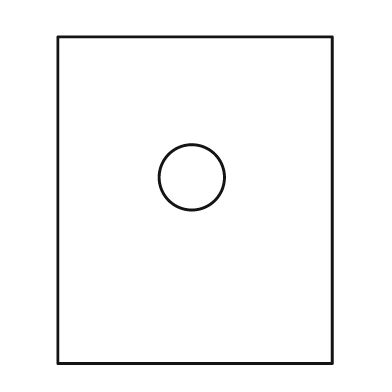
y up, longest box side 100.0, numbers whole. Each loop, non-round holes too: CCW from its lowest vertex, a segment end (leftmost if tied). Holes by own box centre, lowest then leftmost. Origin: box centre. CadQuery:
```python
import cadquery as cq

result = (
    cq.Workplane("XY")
    .moveTo(-42.0, -50.0)
    .lineTo(42.0, -50.0)
    .lineTo(42.0, 50.0)
    .lineTo(-42.0, 50.0)
    .close()
    .moveTo(-1.0, 7.0)
    .circle(10.0)
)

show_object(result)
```